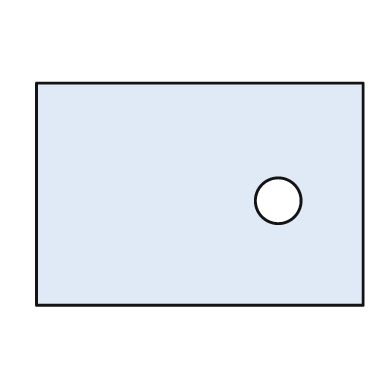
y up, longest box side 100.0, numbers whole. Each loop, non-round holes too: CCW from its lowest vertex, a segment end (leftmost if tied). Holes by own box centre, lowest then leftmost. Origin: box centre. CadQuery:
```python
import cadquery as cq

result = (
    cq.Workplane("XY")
    .moveTo(-50.0, -34.0)
    .lineTo(50.0, -34.0)
    .lineTo(50.0, 34.0)
    .lineTo(-50.0, 34.0)
    .close()
    .moveTo(24.0, -2.0)
    .circle(7.0)
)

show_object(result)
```